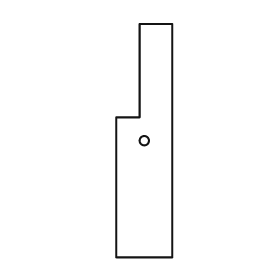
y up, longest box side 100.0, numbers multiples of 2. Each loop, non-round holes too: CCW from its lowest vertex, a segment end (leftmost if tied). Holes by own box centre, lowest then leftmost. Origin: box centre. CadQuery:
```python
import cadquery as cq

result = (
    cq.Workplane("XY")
    .moveTo(-12.0, -50.0)
    .lineTo(12.0, -50.0)
    .lineTo(12.0, 50.0)
    .lineTo(-2.0, 50.0)
    .lineTo(-2.0, 10.0)
    .lineTo(-12.0, 10.0)
    .close()
    .moveTo(0.0, 0.0)
    .circle(2.0)
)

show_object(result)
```